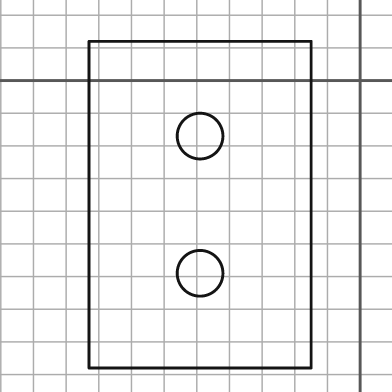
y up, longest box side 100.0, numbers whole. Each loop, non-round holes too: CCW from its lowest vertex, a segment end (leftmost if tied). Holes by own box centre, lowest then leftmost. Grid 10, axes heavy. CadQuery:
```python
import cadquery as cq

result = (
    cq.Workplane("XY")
    .moveTo(-83.0, -88.0)
    .lineTo(-15.0, -88.0)
    .lineTo(-15.0, 12.0)
    .lineTo(-83.0, 12.0)
    .close()
    .moveTo(-49.0, -59.0)
    .circle(7.0)
    .moveTo(-49.0, -17.0)
    .circle(7.0)
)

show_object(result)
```